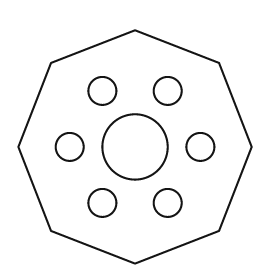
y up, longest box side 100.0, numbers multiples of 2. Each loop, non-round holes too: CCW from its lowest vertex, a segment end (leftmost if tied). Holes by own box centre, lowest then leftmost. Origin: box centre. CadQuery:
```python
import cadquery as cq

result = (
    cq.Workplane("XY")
    .moveTo(0.0, -50.0)
    .lineTo(36.0, -36.0)
    .lineTo(50.0, 0.0)
    .lineTo(36.0, 36.0)
    .lineTo(0.0, 50.0)
    .lineTo(-36.0, 36.0)
    .lineTo(-50.0, 0.0)
    .lineTo(-36.0, -36.0)
    .close()
    .moveTo(-14.0, -24.0)
    .circle(6.0)
    .moveTo(14.0, -24.0)
    .circle(6.0)
    .moveTo(-28.0, 0.0)
    .circle(6.0)
    .moveTo(0.0, 0.0)
    .circle(14.0)
    .moveTo(28.0, 0.0)
    .circle(6.0)
    .moveTo(-14.0, 24.0)
    .circle(6.0)
    .moveTo(14.0, 24.0)
    .circle(6.0)
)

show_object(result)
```